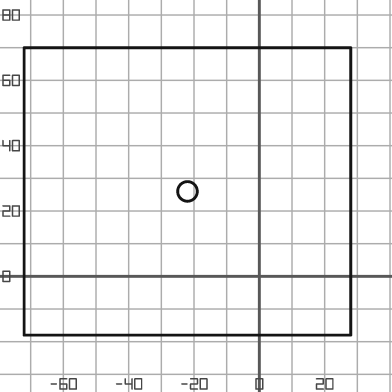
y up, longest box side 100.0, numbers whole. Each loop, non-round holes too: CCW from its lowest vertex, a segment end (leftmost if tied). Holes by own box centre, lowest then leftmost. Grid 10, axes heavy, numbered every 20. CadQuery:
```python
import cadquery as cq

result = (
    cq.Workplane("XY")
    .moveTo(-72.0, -18.0)
    .lineTo(28.0, -18.0)
    .lineTo(28.0, 70.0)
    .lineTo(-72.0, 70.0)
    .close()
    .moveTo(-22.0, 26.0)
    .circle(3.0)
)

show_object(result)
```